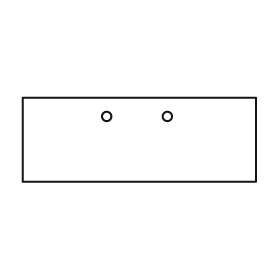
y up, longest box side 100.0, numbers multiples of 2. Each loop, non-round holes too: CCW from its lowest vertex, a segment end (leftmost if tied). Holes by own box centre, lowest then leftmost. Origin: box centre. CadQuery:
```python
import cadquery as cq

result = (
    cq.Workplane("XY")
    .moveTo(-50.0, -18.0)
    .lineTo(50.0, -18.0)
    .lineTo(50.0, 18.0)
    .lineTo(-50.0, 18.0)
    .close()
    .moveTo(-14.0, 10.0)
    .circle(2.0)
    .moveTo(12.0, 10.0)
    .circle(2.0)
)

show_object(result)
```